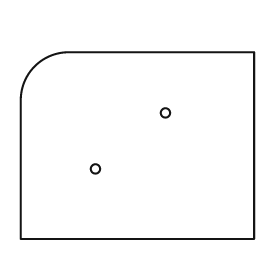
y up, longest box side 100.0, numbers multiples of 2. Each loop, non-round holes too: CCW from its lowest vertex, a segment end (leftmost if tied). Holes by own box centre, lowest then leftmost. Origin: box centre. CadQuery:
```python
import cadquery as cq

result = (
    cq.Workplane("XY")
    .moveTo(-50.0, -40.0)
    .lineTo(50.0, -40.0)
    .lineTo(50.0, 40.0)
    .lineTo(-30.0, 40.0)
    .threePointArc((-44.0, 34.0), (-50.0, 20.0))
    .close()
    .moveTo(-18.0, -10.0)
    .circle(2.0)
    .moveTo(12.0, 14.0)
    .circle(2.0)
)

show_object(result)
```